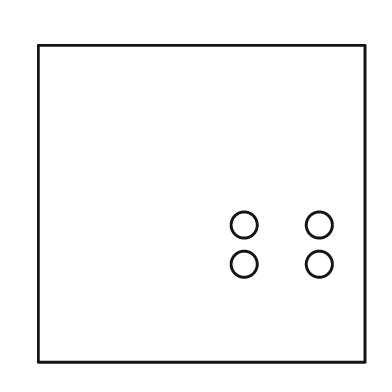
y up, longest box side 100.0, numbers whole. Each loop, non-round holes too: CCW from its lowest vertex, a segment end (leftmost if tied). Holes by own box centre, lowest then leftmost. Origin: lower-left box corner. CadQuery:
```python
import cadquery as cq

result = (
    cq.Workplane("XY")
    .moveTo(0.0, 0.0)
    .lineTo(100.0, 0.0)
    .lineTo(100.0, 97.0)
    .lineTo(0.0, 97.0)
    .close()
    .moveTo(63.0, 30.0)
    .circle(4.0)
    .moveTo(86.0, 30.0)
    .circle(4.0)
    .moveTo(63.0, 42.0)
    .circle(4.0)
    .moveTo(86.0, 42.0)
    .circle(4.0)
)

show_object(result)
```